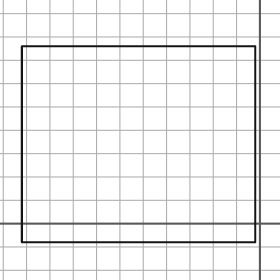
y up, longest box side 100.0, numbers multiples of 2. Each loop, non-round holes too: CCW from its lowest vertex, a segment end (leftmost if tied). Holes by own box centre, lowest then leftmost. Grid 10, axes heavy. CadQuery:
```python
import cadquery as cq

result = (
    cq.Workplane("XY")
    .moveTo(-102.0, -8.0)
    .lineTo(-2.0, -8.0)
    .lineTo(-2.0, 76.0)
    .lineTo(-102.0, 76.0)
    .close()
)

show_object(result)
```